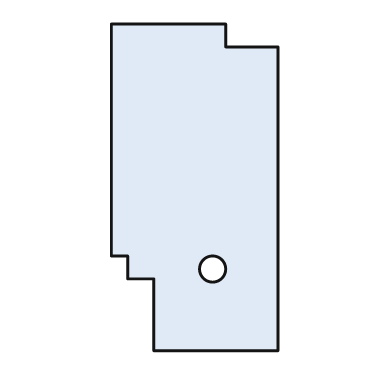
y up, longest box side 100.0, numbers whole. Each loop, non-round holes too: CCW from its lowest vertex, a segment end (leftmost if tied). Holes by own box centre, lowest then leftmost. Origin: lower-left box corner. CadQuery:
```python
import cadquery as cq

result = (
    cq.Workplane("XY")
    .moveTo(13.0, 0.0)
    .lineTo(51.0, 0.0)
    .lineTo(51.0, 93.0)
    .lineTo(35.0, 93.0)
    .lineTo(35.0, 100.0)
    .lineTo(0.0, 100.0)
    .lineTo(0.0, 29.0)
    .lineTo(5.0, 29.0)
    .lineTo(5.0, 22.0)
    .lineTo(13.0, 22.0)
    .close()
    .moveTo(31.0, 25.0)
    .circle(4.0)
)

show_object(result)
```